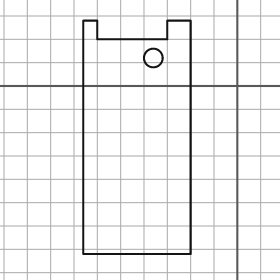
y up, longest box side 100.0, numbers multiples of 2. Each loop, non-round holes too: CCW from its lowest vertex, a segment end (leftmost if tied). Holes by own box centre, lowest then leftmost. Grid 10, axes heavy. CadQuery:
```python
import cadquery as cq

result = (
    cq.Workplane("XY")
    .moveTo(-66.0, -72.0)
    .lineTo(-20.0, -72.0)
    .lineTo(-20.0, 28.0)
    .lineTo(-30.0, 28.0)
    .lineTo(-30.0, 20.0)
    .lineTo(-60.0, 20.0)
    .lineTo(-60.0, 28.0)
    .lineTo(-66.0, 28.0)
    .close()
    .moveTo(-36.0, 12.0)
    .circle(4.0)
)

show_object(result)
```